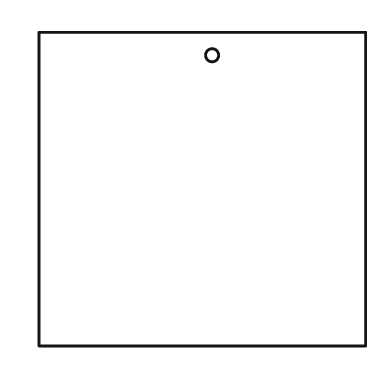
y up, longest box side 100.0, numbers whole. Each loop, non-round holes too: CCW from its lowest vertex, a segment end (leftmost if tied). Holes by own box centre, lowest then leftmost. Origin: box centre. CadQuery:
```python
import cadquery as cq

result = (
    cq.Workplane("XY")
    .moveTo(-50.0, -48.0)
    .lineTo(50.0, -48.0)
    .lineTo(50.0, 48.0)
    .lineTo(-50.0, 48.0)
    .close()
    .moveTo(3.0, 41.0)
    .circle(2.0)
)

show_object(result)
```